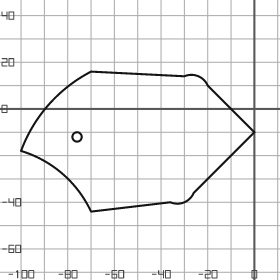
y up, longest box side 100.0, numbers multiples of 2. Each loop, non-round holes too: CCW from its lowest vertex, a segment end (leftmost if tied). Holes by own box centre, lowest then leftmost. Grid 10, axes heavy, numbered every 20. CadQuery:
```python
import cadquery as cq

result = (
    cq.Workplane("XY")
    .moveTo(-70.0, -44.0)
    .lineTo(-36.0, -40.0)
    .threePointArc((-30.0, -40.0), (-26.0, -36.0))
    .lineTo(0.0, -10.0)
    .lineTo(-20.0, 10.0)
    .threePointArc((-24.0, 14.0), (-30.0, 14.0))
    .lineTo(-70.0, 16.0)
    .threePointArc((-88.0, 2.0), (-100.0, -18.0))
    .threePointArc((-82.0, -28.0), (-70.0, -44.0))
    .close()
    .moveTo(-76.0, -12.0)
    .circle(2.0)
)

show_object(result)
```